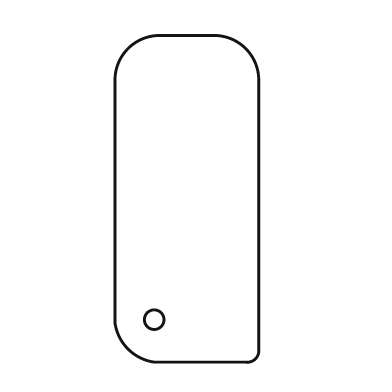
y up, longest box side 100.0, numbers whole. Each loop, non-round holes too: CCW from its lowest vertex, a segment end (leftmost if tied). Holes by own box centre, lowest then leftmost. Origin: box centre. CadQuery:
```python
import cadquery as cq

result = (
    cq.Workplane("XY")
    .moveTo(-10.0, -50.0)
    .lineTo(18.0, -50.0)
    .threePointArc((21.0, -49.0), (22.0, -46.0))
    .lineTo(22.0, 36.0)
    .threePointArc((18.0, 46.0), (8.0, 50.0))
    .lineTo(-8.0, 50.0)
    .threePointArc((-18.0, 46.0), (-22.0, 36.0))
    .lineTo(-22.0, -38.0)
    .threePointArc((-18.0, -46.0), (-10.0, -50.0))
    .close()
    .moveTo(-10.0, -37.0)
    .circle(3.0)
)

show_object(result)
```